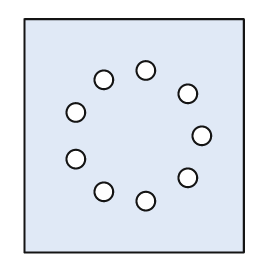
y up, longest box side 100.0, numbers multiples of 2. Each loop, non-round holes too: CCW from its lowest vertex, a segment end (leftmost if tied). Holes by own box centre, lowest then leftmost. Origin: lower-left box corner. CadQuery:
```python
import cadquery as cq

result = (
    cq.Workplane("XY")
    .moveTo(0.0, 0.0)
    .lineTo(94.0, 0.0)
    .lineTo(94.0, 100.0)
    .lineTo(0.0, 100.0)
    .close()
    .moveTo(52.0, 22.0)
    .circle(4.0)
    .moveTo(34.0, 26.0)
    .circle(4.0)
    .moveTo(70.0, 32.0)
    .circle(4.0)
    .moveTo(22.0, 40.0)
    .circle(4.0)
    .moveTo(76.0, 50.0)
    .circle(4.0)
    .moveTo(22.0, 60.0)
    .circle(4.0)
    .moveTo(70.0, 68.0)
    .circle(4.0)
    .moveTo(34.0, 74.0)
    .circle(4.0)
    .moveTo(52.0, 78.0)
    .circle(4.0)
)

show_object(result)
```